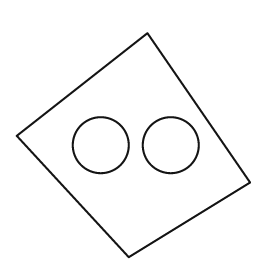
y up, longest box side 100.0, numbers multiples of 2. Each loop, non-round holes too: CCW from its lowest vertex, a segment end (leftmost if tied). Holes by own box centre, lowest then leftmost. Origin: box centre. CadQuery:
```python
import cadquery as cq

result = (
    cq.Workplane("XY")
    .moveTo(-2.0, -48.0)
    .lineTo(50.0, -16.0)
    .lineTo(6.0, 48.0)
    .lineTo(-50.0, 4.0)
    .close()
    .moveTo(-14.0, 0.0)
    .circle(12.0)
    .moveTo(16.0, 0.0)
    .circle(12.0)
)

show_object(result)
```